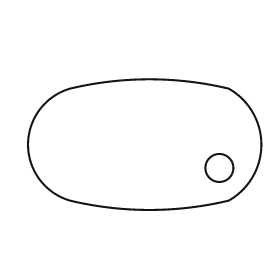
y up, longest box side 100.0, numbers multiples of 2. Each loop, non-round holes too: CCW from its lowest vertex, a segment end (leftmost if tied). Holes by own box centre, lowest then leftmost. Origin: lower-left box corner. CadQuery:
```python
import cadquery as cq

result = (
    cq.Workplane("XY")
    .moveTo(18.0, 4.0)
    .threePointArc((52.0, 0.0), (86.0, 4.0))
    .threePointArc((100.0, 28.0), (86.0, 52.0))
    .threePointArc((52.0, 56.0), (18.0, 52.0))
    .threePointArc((0.0, 28.0), (18.0, 4.0))
    .close()
    .moveTo(82.0, 18.0)
    .circle(6.0)
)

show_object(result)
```